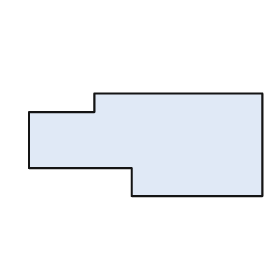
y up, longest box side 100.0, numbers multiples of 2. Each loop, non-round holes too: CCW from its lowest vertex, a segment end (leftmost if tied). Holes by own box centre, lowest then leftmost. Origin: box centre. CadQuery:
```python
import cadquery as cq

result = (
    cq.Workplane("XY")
    .moveTo(-6.0, -22.0)
    .lineTo(50.0, -22.0)
    .lineTo(50.0, 22.0)
    .lineTo(-22.0, 22.0)
    .lineTo(-22.0, 14.0)
    .lineTo(-50.0, 14.0)
    .lineTo(-50.0, -10.0)
    .lineTo(-6.0, -10.0)
    .close()
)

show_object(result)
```